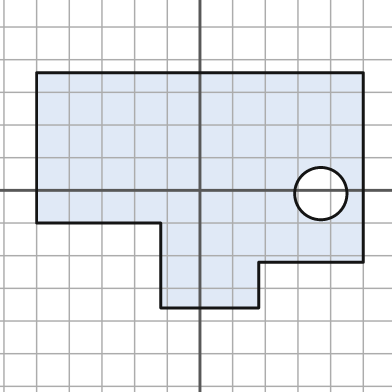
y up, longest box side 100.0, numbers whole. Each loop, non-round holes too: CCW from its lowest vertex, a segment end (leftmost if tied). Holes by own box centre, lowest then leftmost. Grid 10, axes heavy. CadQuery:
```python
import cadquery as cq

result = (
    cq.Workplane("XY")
    .moveTo(-12.0, -36.0)
    .lineTo(18.0, -36.0)
    .lineTo(18.0, -22.0)
    .lineTo(50.0, -22.0)
    .lineTo(50.0, 36.0)
    .lineTo(-50.0, 36.0)
    .lineTo(-50.0, -10.0)
    .lineTo(-12.0, -10.0)
    .close()
    .moveTo(37.0, -1.0)
    .circle(8.0)
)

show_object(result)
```